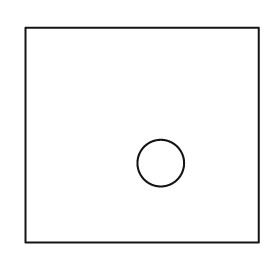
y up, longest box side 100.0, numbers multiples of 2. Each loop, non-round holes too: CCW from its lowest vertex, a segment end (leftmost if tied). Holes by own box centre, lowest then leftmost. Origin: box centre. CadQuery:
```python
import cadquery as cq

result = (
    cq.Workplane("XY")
    .moveTo(-50.0, -46.0)
    .lineTo(50.0, -46.0)
    .lineTo(50.0, 46.0)
    .lineTo(-50.0, 46.0)
    .close()
    .moveTo(8.0, -12.0)
    .circle(10.0)
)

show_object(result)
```